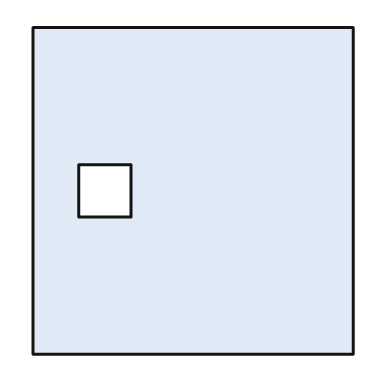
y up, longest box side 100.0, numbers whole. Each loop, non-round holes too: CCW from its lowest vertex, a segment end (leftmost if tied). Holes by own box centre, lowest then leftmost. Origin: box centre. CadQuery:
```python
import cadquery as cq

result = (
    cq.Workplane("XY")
    .moveTo(-49.0, -50.0)
    .lineTo(49.0, -50.0)
    .lineTo(49.0, 50.0)
    .lineTo(-49.0, 50.0)
    .close()
    .moveTo(-35.0, -8.0)
    .lineTo(-19.0, -8.0)
    .lineTo(-19.0, 8.0)
    .lineTo(-35.0, 8.0)
    .close()
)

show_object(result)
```